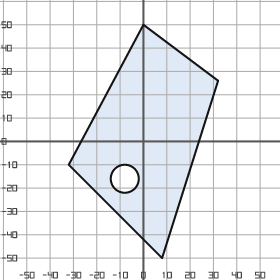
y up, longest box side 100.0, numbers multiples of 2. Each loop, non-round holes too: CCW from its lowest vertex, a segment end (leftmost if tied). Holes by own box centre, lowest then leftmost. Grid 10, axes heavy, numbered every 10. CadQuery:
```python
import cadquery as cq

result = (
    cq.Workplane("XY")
    .moveTo(8.0, -50.0)
    .lineTo(32.0, 26.0)
    .lineTo(0.0, 50.0)
    .lineTo(-32.0, -10.0)
    .close()
    .moveTo(-8.0, -16.0)
    .circle(6.0)
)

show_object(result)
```